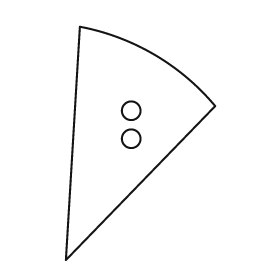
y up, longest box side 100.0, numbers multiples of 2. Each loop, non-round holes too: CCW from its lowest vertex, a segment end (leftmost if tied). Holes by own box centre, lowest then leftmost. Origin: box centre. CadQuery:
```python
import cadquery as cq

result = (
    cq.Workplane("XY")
    .moveTo(-32.0, -50.0)
    .lineTo(32.0, 16.0)
    .threePointArc((6.0, 38.0), (-26.0, 50.0))
    .close()
    .moveTo(-4.0, 2.0)
    .circle(4.0)
    .moveTo(-4.0, 14.0)
    .circle(4.0)
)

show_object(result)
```